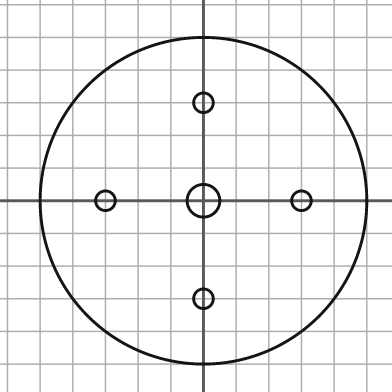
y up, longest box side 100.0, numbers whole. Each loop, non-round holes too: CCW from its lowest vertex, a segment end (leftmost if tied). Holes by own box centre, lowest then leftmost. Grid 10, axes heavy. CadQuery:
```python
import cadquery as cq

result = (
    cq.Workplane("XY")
    .moveTo(0.0, 0.0)
    .circle(50.0)
    .moveTo(0.0, -30.0)
    .circle(3.0)
    .moveTo(-30.0, 0.0)
    .circle(3.0)
    .moveTo(0.0, 0.0)
    .circle(5.0)
    .moveTo(30.0, 0.0)
    .circle(3.0)
    .moveTo(0.0, 30.0)
    .circle(3.0)
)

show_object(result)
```